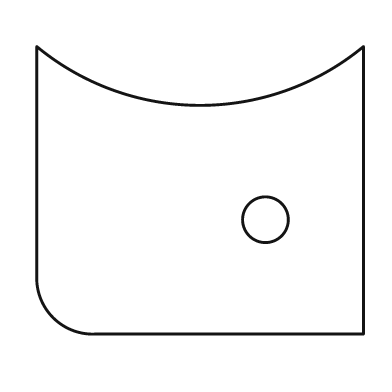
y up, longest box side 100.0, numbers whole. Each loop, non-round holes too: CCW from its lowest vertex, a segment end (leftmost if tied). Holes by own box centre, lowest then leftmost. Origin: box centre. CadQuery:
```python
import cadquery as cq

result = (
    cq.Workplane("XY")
    .moveTo(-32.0, -44.0)
    .lineTo(50.0, -44.0)
    .lineTo(50.0, 44.0)
    .threePointArc((0.0, 26.0), (-50.0, 44.0))
    .lineTo(-50.0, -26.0)
    .threePointArc((-45.0, -39.0), (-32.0, -44.0))
    .close()
    .moveTo(20.0, -9.0)
    .circle(7.0)
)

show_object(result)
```